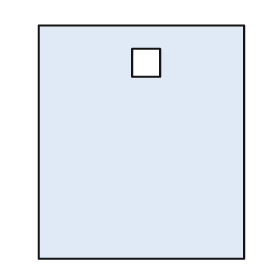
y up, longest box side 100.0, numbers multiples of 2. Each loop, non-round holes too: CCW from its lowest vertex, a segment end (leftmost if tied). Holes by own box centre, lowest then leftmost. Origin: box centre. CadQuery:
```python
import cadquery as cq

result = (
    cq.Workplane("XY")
    .moveTo(-44.0, -50.0)
    .lineTo(44.0, -50.0)
    .lineTo(44.0, 50.0)
    .lineTo(-44.0, 50.0)
    .close()
    .moveTo(-4.0, 28.0)
    .lineTo(8.0, 28.0)
    .lineTo(8.0, 40.0)
    .lineTo(-4.0, 40.0)
    .close()
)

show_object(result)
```